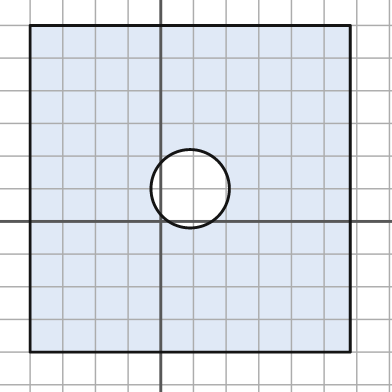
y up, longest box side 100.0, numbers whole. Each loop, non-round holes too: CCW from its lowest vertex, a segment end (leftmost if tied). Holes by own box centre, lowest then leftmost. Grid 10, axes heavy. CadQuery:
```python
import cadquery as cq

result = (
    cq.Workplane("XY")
    .moveTo(-40.0, -40.0)
    .lineTo(58.0, -40.0)
    .lineTo(58.0, 60.0)
    .lineTo(-40.0, 60.0)
    .close()
    .moveTo(9.0, 10.0)
    .circle(12.0)
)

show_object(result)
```